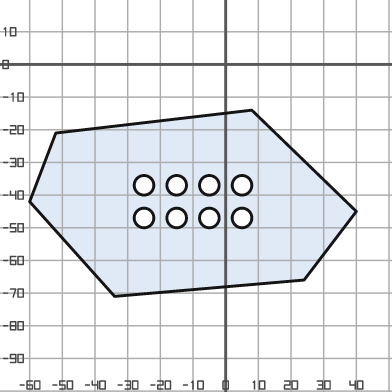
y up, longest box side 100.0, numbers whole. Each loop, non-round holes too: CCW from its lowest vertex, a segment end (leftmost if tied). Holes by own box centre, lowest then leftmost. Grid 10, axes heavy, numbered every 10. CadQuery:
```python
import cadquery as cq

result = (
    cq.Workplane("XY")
    .moveTo(-34.0, -71.0)
    .lineTo(24.0, -66.0)
    .lineTo(40.0, -45.0)
    .lineTo(8.0, -14.0)
    .lineTo(-52.0, -21.0)
    .lineTo(-60.0, -42.0)
    .close()
    .moveTo(-25.0, -47.0)
    .circle(3.0)
    .moveTo(-15.0, -47.0)
    .circle(3.0)
    .moveTo(-5.0, -47.0)
    .circle(3.0)
    .moveTo(5.0, -47.0)
    .circle(3.0)
    .moveTo(-25.0, -37.0)
    .circle(3.0)
    .moveTo(-15.0, -37.0)
    .circle(3.0)
    .moveTo(-5.0, -37.0)
    .circle(3.0)
    .moveTo(5.0, -37.0)
    .circle(3.0)
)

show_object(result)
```